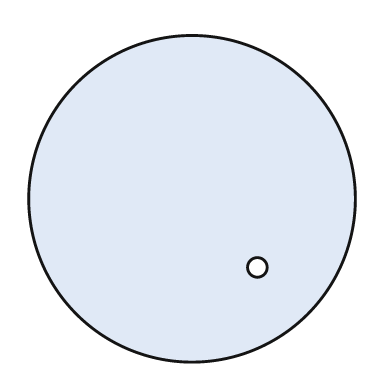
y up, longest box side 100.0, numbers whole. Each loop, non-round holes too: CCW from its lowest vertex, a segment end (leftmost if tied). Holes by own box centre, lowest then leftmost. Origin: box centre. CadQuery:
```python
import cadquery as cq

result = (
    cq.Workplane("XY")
    .moveTo(0.0, 0.0)
    .circle(50.0)
    .moveTo(20.0, -21.0)
    .circle(3.0)
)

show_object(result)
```